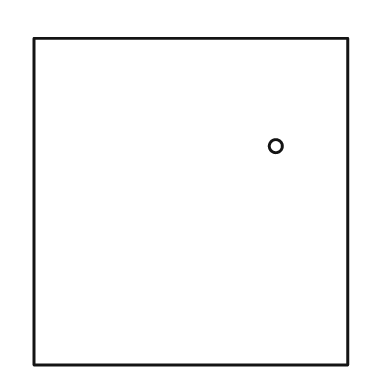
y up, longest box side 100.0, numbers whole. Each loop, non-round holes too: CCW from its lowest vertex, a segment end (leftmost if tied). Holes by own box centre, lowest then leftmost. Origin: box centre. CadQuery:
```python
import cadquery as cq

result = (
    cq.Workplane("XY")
    .moveTo(-48.0, -50.0)
    .lineTo(48.0, -50.0)
    .lineTo(48.0, 50.0)
    .lineTo(-48.0, 50.0)
    .close()
    .moveTo(26.0, 17.0)
    .circle(2.0)
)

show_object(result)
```